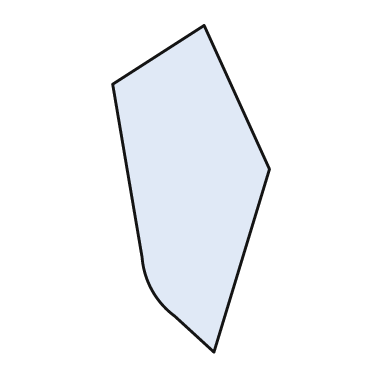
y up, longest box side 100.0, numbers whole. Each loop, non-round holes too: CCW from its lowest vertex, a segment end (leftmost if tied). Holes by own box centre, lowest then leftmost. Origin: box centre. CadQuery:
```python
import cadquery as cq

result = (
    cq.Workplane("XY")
    .moveTo(7.0, -50.0)
    .lineTo(24.0, 6.0)
    .lineTo(4.0, 50.0)
    .lineTo(-24.0, 32.0)
    .lineTo(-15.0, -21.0)
    .threePointArc((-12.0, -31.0), (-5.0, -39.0))
    .close()
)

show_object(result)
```